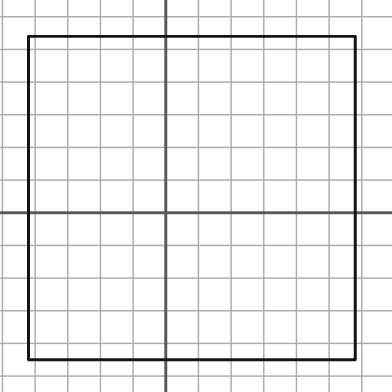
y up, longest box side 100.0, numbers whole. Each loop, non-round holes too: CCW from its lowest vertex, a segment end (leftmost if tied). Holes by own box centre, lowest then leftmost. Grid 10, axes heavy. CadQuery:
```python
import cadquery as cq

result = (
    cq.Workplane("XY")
    .moveTo(-42.0, -45.0)
    .lineTo(58.0, -45.0)
    .lineTo(58.0, 54.0)
    .lineTo(-42.0, 54.0)
    .close()
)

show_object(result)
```